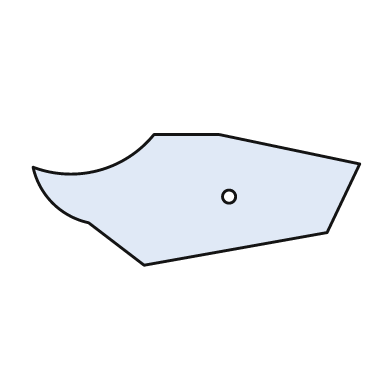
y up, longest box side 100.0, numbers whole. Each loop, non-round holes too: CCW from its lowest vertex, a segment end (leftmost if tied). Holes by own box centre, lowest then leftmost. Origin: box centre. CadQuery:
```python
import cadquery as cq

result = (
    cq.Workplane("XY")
    .moveTo(-16.0, -20.0)
    .lineTo(40.0, -10.0)
    .lineTo(50.0, 11.0)
    .lineTo(7.0, 20.0)
    .lineTo(-13.0, 20.0)
    .threePointArc((-30.0, 9.0), (-50.0, 10.0))
    .threePointArc((-44.0, -1.0), (-33.0, -7.0))
    .close()
    .moveTo(10.0, 1.0)
    .circle(2.0)
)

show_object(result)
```